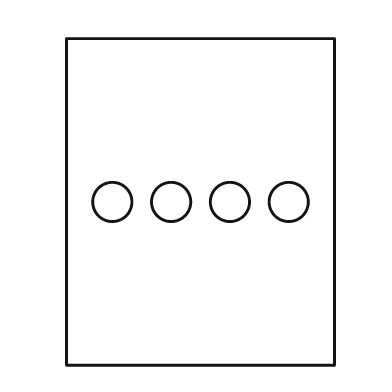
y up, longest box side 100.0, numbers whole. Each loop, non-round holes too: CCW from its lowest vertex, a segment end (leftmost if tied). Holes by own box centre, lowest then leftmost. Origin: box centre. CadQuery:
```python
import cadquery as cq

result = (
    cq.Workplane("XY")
    .moveTo(-41.0, -50.0)
    .lineTo(41.0, -50.0)
    .lineTo(41.0, 50.0)
    .lineTo(-41.0, 50.0)
    .close()
    .moveTo(-27.0, 0.0)
    .circle(6.0)
    .moveTo(-9.0, 0.0)
    .circle(6.0)
    .moveTo(9.0, 0.0)
    .circle(6.0)
    .moveTo(27.0, 0.0)
    .circle(6.0)
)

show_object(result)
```